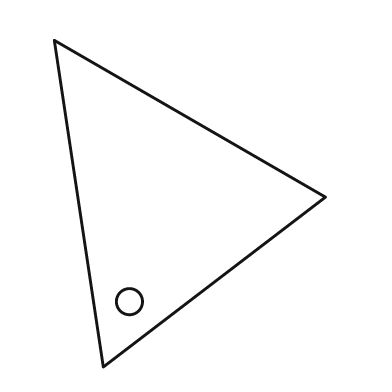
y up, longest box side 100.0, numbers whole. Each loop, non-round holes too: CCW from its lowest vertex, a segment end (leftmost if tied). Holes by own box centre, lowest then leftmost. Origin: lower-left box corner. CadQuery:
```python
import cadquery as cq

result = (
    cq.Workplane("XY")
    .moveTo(15.0, 0.0)
    .lineTo(83.0, 52.0)
    .lineTo(0.0, 100.0)
    .close()
    .moveTo(23.0, 20.0)
    .circle(4.0)
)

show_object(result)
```